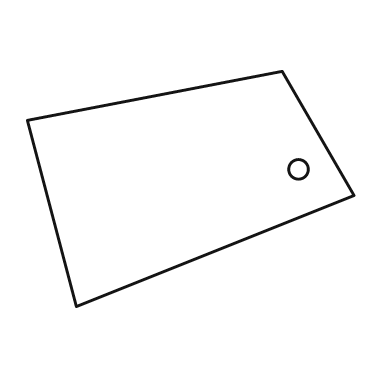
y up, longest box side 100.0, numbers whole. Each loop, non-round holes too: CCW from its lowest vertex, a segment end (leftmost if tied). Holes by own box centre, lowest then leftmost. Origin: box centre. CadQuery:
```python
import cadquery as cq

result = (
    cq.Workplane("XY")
    .moveTo(-35.0, -36.0)
    .lineTo(50.0, -2.0)
    .lineTo(28.0, 36.0)
    .lineTo(-50.0, 21.0)
    .close()
    .moveTo(33.0, 6.0)
    .circle(3.0)
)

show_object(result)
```